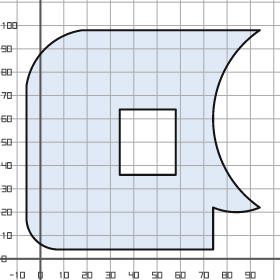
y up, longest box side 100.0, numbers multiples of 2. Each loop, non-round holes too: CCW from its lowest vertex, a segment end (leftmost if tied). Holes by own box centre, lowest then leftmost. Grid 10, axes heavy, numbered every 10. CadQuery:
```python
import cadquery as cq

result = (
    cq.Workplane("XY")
    .moveTo(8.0, 4.0)
    .lineTo(74.0, 4.0)
    .lineTo(74.0, 22.0)
    .threePointArc((84.0, 20.0), (94.0, 22.0))
    .threePointArc((74.0, 60.0), (94.0, 98.0))
    .lineTo(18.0, 98.0)
    .threePointArc((2.0, 90.0), (-6.0, 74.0))
    .lineTo(-6.0, 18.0)
    .threePointArc((-2.0, 8.0), (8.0, 4.0))
    .close()
    .moveTo(34.0, 36.0)
    .lineTo(58.0, 36.0)
    .lineTo(58.0, 64.0)
    .lineTo(34.0, 64.0)
    .close()
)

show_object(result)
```